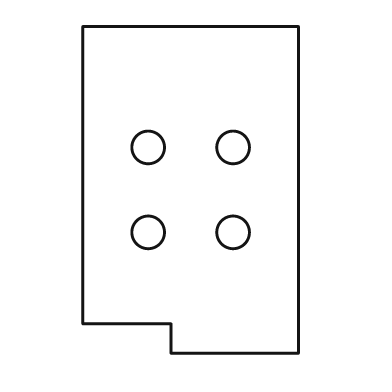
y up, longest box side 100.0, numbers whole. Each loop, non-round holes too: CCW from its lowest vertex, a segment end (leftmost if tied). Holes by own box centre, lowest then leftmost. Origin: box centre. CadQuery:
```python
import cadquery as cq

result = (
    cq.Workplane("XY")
    .moveTo(-6.0, -50.0)
    .lineTo(33.0, -50.0)
    .lineTo(33.0, 50.0)
    .lineTo(-33.0, 50.0)
    .lineTo(-33.0, -41.0)
    .lineTo(-6.0, -41.0)
    .close()
    .moveTo(-13.0, -13.0)
    .circle(5.0)
    .moveTo(13.0, -13.0)
    .circle(5.0)
    .moveTo(-13.0, 13.0)
    .circle(5.0)
    .moveTo(13.0, 13.0)
    .circle(5.0)
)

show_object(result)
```